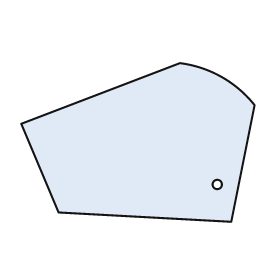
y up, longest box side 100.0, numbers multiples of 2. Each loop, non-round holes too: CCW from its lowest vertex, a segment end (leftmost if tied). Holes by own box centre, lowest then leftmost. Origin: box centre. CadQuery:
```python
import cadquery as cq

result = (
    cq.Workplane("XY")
    .moveTo(40.0, -34.0)
    .lineTo(50.0, 16.0)
    .threePointArc((36.0, 28.0), (18.0, 34.0))
    .lineTo(-50.0, 8.0)
    .lineTo(-34.0, -30.0)
    .close()
    .moveTo(34.0, -18.0)
    .circle(2.0)
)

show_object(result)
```